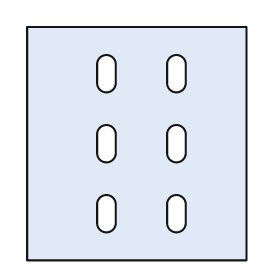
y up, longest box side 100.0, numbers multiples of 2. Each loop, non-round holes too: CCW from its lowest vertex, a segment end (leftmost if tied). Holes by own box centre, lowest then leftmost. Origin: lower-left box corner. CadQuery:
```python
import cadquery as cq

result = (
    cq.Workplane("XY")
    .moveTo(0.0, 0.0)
    .lineTo(94.0, 0.0)
    .lineTo(94.0, 100.0)
    .lineTo(0.0, 100.0)
    .close()
    .moveTo(30.0, 16.0)
    .threePointArc((34.0, 12.0), (38.0, 16.0))
    .lineTo(38.0, 24.0)
    .threePointArc((34.0, 28.0), (30.0, 24.0))
    .close()
    .moveTo(60.0, 16.0)
    .threePointArc((64.0, 12.0), (68.0, 16.0))
    .lineTo(68.0, 24.0)
    .threePointArc((64.0, 28.0), (60.0, 24.0))
    .close()
    .moveTo(30.0, 46.0)
    .threePointArc((34.0, 42.0), (38.0, 46.0))
    .lineTo(38.0, 54.0)
    .threePointArc((34.0, 58.0), (30.0, 54.0))
    .close()
    .moveTo(60.0, 46.0)
    .threePointArc((64.0, 42.0), (68.0, 46.0))
    .lineTo(68.0, 54.0)
    .threePointArc((64.0, 58.0), (60.0, 54.0))
    .close()
    .moveTo(30.0, 76.0)
    .threePointArc((34.0, 72.0), (38.0, 76.0))
    .lineTo(38.0, 84.0)
    .threePointArc((34.0, 88.0), (30.0, 84.0))
    .close()
    .moveTo(60.0, 76.0)
    .threePointArc((64.0, 72.0), (68.0, 76.0))
    .lineTo(68.0, 84.0)
    .threePointArc((64.0, 88.0), (60.0, 84.0))
    .close()
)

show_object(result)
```